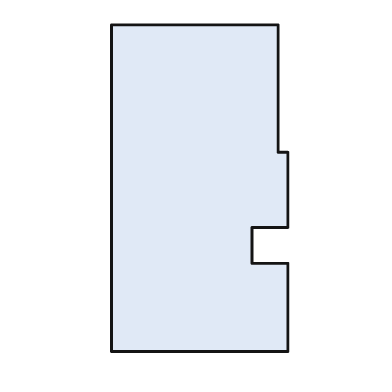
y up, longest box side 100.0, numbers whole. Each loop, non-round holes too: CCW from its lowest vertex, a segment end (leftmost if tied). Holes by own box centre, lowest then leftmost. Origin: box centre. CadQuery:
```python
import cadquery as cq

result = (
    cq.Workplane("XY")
    .moveTo(-27.0, -50.0)
    .lineTo(27.0, -50.0)
    .lineTo(27.0, -23.0)
    .lineTo(16.0, -23.0)
    .lineTo(16.0, -12.0)
    .lineTo(27.0, -12.0)
    .lineTo(27.0, 11.0)
    .lineTo(24.0, 11.0)
    .lineTo(24.0, 50.0)
    .lineTo(-27.0, 50.0)
    .close()
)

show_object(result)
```